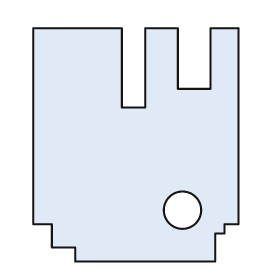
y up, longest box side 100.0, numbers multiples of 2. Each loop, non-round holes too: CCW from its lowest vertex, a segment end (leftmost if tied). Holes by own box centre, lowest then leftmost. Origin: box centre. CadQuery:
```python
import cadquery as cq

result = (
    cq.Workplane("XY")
    .moveTo(-26.0, -50.0)
    .lineTo(34.0, -50.0)
    .lineTo(34.0, -38.0)
    .lineTo(38.0, -38.0)
    .lineTo(38.0, -34.0)
    .lineTo(44.0, -34.0)
    .lineTo(44.0, 50.0)
    .lineTo(32.0, 50.0)
    .lineTo(32.0, 24.0)
    .lineTo(18.0, 24.0)
    .lineTo(18.0, 50.0)
    .lineTo(4.0, 50.0)
    .lineTo(4.0, 16.0)
    .lineTo(-6.0, 16.0)
    .lineTo(-6.0, 50.0)
    .lineTo(-44.0, 50.0)
    .lineTo(-44.0, -34.0)
    .lineTo(-36.0, -34.0)
    .lineTo(-36.0, -44.0)
    .lineTo(-26.0, -44.0)
    .close()
    .moveTo(20.0, -28.0)
    .circle(8.0)
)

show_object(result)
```